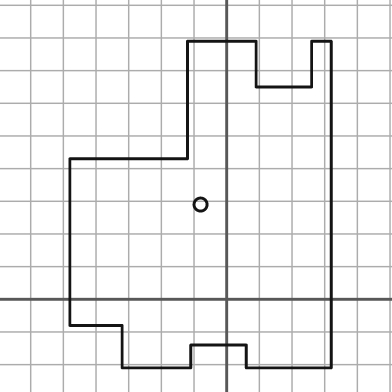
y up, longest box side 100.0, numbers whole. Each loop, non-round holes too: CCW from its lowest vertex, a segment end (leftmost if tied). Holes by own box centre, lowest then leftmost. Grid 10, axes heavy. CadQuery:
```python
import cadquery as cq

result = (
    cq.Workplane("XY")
    .moveTo(-32.0, -21.0)
    .lineTo(-11.0, -21.0)
    .lineTo(-11.0, -14.0)
    .lineTo(6.0, -14.0)
    .lineTo(6.0, -21.0)
    .lineTo(32.0, -21.0)
    .lineTo(32.0, 79.0)
    .lineTo(26.0, 79.0)
    .lineTo(26.0, 65.0)
    .lineTo(9.0, 65.0)
    .lineTo(9.0, 79.0)
    .lineTo(-12.0, 79.0)
    .lineTo(-12.0, 43.0)
    .lineTo(-48.0, 43.0)
    .lineTo(-48.0, -8.0)
    .lineTo(-32.0, -8.0)
    .close()
    .moveTo(-8.0, 29.0)
    .circle(2.0)
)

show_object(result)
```